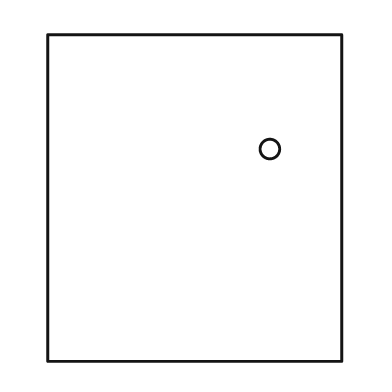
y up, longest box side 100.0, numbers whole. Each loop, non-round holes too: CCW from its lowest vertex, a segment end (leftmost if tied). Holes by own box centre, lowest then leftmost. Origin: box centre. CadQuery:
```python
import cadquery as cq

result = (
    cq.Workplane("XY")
    .moveTo(-45.0, -50.0)
    .lineTo(45.0, -50.0)
    .lineTo(45.0, 50.0)
    .lineTo(-45.0, 50.0)
    .close()
    .moveTo(23.0, 15.0)
    .circle(3.0)
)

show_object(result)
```